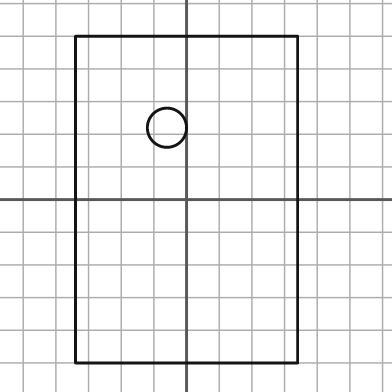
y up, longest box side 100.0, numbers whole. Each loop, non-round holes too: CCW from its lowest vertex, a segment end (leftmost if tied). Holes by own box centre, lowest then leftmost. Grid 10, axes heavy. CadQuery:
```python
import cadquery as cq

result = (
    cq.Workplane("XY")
    .moveTo(-34.0, -50.0)
    .lineTo(34.0, -50.0)
    .lineTo(34.0, 50.0)
    .lineTo(-34.0, 50.0)
    .close()
    .moveTo(-6.0, 22.0)
    .circle(6.0)
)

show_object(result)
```